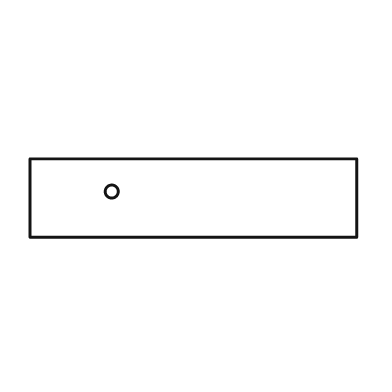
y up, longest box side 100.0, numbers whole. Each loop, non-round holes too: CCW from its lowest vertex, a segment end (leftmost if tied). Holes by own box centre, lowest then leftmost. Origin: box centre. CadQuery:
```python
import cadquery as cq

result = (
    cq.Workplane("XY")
    .moveTo(-50.0, -12.0)
    .lineTo(50.0, -12.0)
    .lineTo(50.0, 12.0)
    .lineTo(-50.0, 12.0)
    .close()
    .moveTo(-25.0, 2.0)
    .circle(2.0)
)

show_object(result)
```